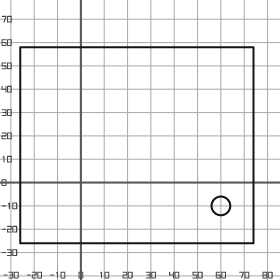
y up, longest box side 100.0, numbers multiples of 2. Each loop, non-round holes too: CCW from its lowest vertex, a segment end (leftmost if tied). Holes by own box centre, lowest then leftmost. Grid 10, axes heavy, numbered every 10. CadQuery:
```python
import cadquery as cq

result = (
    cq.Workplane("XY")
    .moveTo(-26.0, -26.0)
    .lineTo(74.0, -26.0)
    .lineTo(74.0, 58.0)
    .lineTo(-26.0, 58.0)
    .close()
    .moveTo(60.0, -10.0)
    .circle(4.0)
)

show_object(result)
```